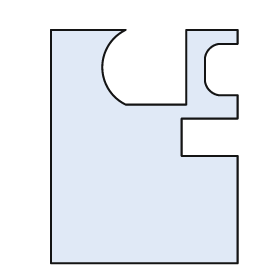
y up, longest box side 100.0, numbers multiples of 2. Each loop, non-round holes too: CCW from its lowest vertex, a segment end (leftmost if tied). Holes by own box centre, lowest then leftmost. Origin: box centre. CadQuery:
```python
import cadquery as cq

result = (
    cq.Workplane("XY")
    .moveTo(-40.0, -50.0)
    .lineTo(40.0, -50.0)
    .lineTo(40.0, -4.0)
    .lineTo(16.0, -4.0)
    .lineTo(16.0, 12.0)
    .lineTo(40.0, 12.0)
    .lineTo(40.0, 22.0)
    .lineTo(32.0, 22.0)
    .threePointArc((28.0, 24.0), (26.0, 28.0))
    .lineTo(26.0, 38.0)
    .threePointArc((28.0, 42.0), (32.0, 44.0))
    .lineTo(40.0, 44.0)
    .lineTo(40.0, 50.0)
    .lineTo(18.0, 50.0)
    .lineTo(18.0, 18.0)
    .lineTo(-8.0, 18.0)
    .threePointArc((-18.0, 34.0), (-8.0, 50.0))
    .lineTo(-40.0, 50.0)
    .close()
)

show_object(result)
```